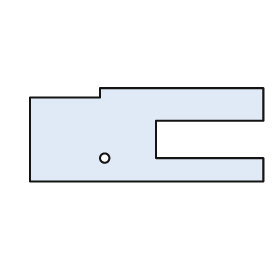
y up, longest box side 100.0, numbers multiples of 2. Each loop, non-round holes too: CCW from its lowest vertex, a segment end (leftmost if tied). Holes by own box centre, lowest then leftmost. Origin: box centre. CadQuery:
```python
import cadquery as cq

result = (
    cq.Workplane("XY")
    .moveTo(-50.0, -20.0)
    .lineTo(50.0, -20.0)
    .lineTo(50.0, -10.0)
    .lineTo(4.0, -10.0)
    .lineTo(4.0, 6.0)
    .lineTo(50.0, 6.0)
    .lineTo(50.0, 20.0)
    .lineTo(-20.0, 20.0)
    .lineTo(-20.0, 16.0)
    .lineTo(-50.0, 16.0)
    .close()
    .moveTo(-18.0, -10.0)
    .circle(2.0)
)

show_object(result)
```